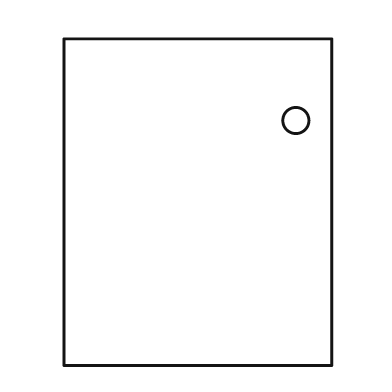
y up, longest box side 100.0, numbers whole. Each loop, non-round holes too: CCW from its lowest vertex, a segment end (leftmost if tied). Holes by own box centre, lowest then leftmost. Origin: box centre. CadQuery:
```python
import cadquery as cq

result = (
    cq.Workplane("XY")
    .moveTo(-41.0, -50.0)
    .lineTo(41.0, -50.0)
    .lineTo(41.0, 50.0)
    .lineTo(-41.0, 50.0)
    .close()
    .moveTo(30.0, 25.0)
    .circle(4.0)
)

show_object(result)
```